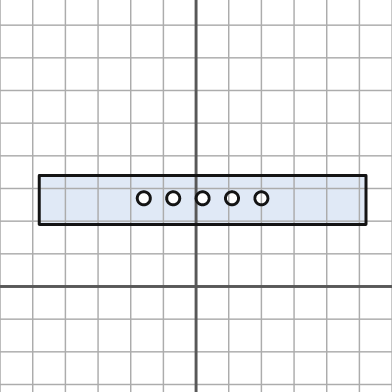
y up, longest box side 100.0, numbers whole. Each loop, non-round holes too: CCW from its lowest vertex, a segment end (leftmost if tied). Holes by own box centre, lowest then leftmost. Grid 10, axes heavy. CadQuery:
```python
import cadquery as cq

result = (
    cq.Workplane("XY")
    .moveTo(-48.0, 19.0)
    .lineTo(52.0, 19.0)
    .lineTo(52.0, 34.0)
    .lineTo(-48.0, 34.0)
    .close()
    .moveTo(-16.0, 27.0)
    .circle(2.0)
    .moveTo(-7.0, 27.0)
    .circle(2.0)
    .moveTo(2.0, 27.0)
    .circle(2.0)
    .moveTo(11.0, 27.0)
    .circle(2.0)
    .moveTo(20.0, 27.0)
    .circle(2.0)
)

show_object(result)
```